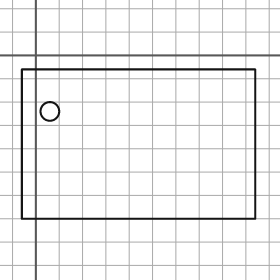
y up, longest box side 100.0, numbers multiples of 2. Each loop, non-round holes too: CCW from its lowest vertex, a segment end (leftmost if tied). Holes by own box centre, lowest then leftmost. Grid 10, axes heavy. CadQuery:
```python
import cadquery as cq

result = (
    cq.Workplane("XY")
    .moveTo(-6.0, -70.0)
    .lineTo(94.0, -70.0)
    .lineTo(94.0, -6.0)
    .lineTo(-6.0, -6.0)
    .close()
    .moveTo(6.0, -24.0)
    .circle(4.0)
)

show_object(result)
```